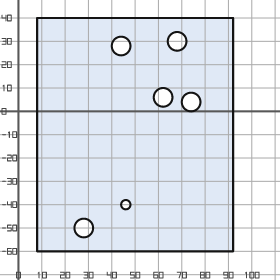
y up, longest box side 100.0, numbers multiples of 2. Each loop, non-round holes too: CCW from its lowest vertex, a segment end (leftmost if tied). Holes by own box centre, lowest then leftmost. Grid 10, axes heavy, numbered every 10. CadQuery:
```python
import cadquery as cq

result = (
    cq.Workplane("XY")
    .moveTo(8.0, -60.0)
    .lineTo(92.0, -60.0)
    .lineTo(92.0, 40.0)
    .lineTo(8.0, 40.0)
    .close()
    .moveTo(28.0, -50.0)
    .circle(4.0)
    .moveTo(46.0, -40.0)
    .circle(2.0)
    .moveTo(74.0, 4.0)
    .circle(4.0)
    .moveTo(62.0, 6.0)
    .circle(4.0)
    .moveTo(44.0, 28.0)
    .circle(4.0)
    .moveTo(68.0, 30.0)
    .circle(4.0)
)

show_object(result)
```